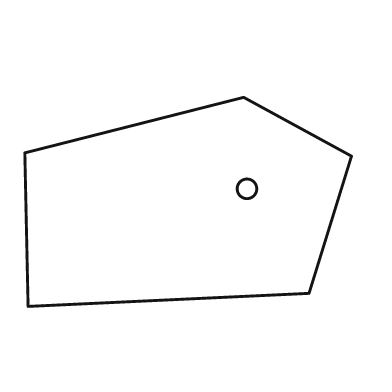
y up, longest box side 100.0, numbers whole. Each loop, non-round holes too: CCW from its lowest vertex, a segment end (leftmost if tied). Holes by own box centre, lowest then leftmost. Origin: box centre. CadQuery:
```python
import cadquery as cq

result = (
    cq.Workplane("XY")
    .moveTo(-49.0, -32.0)
    .lineTo(37.0, -28.0)
    .lineTo(50.0, 14.0)
    .lineTo(17.0, 32.0)
    .lineTo(-50.0, 15.0)
    .close()
    .moveTo(18.0, 4.0)
    .circle(3.0)
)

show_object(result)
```